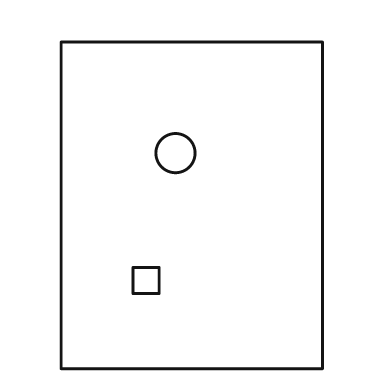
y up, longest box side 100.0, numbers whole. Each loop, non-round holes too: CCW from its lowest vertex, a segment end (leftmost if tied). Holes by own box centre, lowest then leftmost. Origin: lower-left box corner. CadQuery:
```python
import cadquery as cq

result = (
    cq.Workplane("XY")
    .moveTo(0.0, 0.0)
    .lineTo(80.0, 0.0)
    .lineTo(80.0, 100.0)
    .lineTo(0.0, 100.0)
    .close()
    .moveTo(22.0, 23.0)
    .lineTo(30.0, 23.0)
    .lineTo(30.0, 31.0)
    .lineTo(22.0, 31.0)
    .close()
    .moveTo(35.0, 66.0)
    .circle(6.0)
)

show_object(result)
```